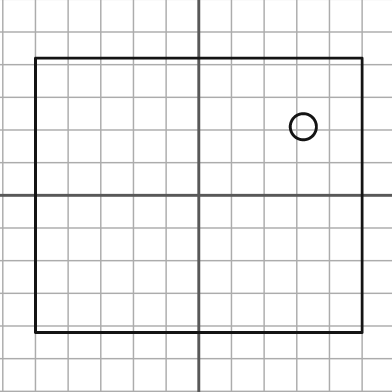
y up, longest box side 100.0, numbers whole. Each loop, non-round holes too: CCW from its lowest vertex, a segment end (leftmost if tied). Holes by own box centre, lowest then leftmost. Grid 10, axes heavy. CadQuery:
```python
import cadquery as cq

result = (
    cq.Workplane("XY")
    .moveTo(-50.0, -42.0)
    .lineTo(50.0, -42.0)
    .lineTo(50.0, 42.0)
    .lineTo(-50.0, 42.0)
    .close()
    .moveTo(32.0, 21.0)
    .circle(4.0)
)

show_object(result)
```